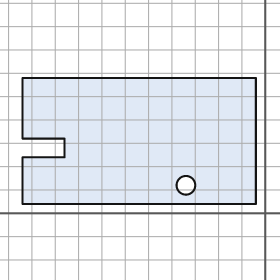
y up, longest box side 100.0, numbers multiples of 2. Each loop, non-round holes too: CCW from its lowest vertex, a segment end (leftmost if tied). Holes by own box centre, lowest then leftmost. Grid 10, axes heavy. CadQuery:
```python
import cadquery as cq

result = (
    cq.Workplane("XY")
    .moveTo(-104.0, 4.0)
    .lineTo(-4.0, 4.0)
    .lineTo(-4.0, 58.0)
    .lineTo(-104.0, 58.0)
    .lineTo(-104.0, 32.0)
    .lineTo(-86.0, 32.0)
    .lineTo(-86.0, 24.0)
    .lineTo(-104.0, 24.0)
    .close()
    .moveTo(-34.0, 12.0)
    .circle(4.0)
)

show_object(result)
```